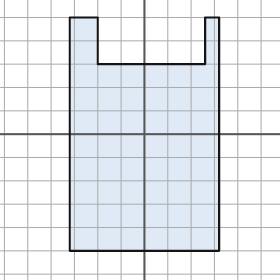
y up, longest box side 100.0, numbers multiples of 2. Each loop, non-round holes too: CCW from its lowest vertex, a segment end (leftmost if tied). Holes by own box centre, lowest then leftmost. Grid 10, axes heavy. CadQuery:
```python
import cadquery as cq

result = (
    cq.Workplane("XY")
    .moveTo(-32.0, -50.0)
    .lineTo(32.0, -50.0)
    .lineTo(32.0, 50.0)
    .lineTo(26.0, 50.0)
    .lineTo(26.0, 30.0)
    .lineTo(-20.0, 30.0)
    .lineTo(-20.0, 50.0)
    .lineTo(-32.0, 50.0)
    .close()
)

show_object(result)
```